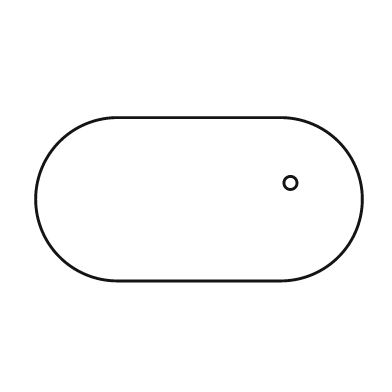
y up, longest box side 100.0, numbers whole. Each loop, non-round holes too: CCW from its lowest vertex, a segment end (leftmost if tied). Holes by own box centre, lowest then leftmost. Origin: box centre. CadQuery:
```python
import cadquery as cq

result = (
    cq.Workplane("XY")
    .moveTo(-25.0, -25.0)
    .lineTo(25.0, -25.0)
    .threePointArc((50.0, 0.0), (25.0, 25.0))
    .lineTo(-25.0, 25.0)
    .threePointArc((-50.0, 0.0), (-25.0, -25.0))
    .close()
    .moveTo(28.0, 5.0)
    .circle(2.0)
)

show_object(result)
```